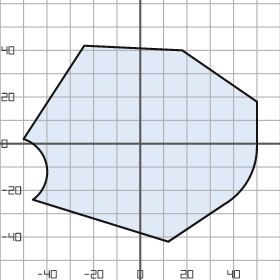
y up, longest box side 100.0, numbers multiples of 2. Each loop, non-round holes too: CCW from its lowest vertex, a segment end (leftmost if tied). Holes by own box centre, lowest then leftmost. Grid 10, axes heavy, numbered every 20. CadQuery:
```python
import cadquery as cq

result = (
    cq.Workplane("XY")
    .moveTo(12.0, -42.0)
    .lineTo(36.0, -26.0)
    .threePointArc((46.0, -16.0), (50.0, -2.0))
    .lineTo(50.0, 18.0)
    .lineTo(18.0, 40.0)
    .lineTo(-24.0, 42.0)
    .lineTo(-50.0, 2.0)
    .threePointArc((-40.0, -10.0), (-46.0, -24.0))
    .close()
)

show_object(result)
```